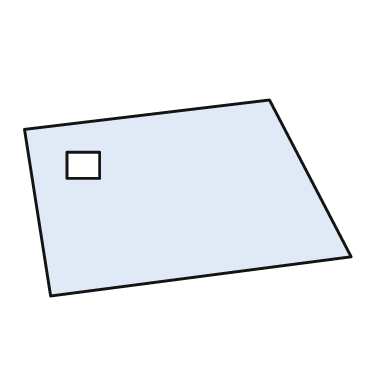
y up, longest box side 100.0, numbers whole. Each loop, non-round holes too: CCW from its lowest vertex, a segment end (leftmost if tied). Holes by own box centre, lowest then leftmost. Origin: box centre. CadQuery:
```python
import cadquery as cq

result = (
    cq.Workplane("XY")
    .moveTo(-42.0, -30.0)
    .lineTo(50.0, -18.0)
    .lineTo(25.0, 30.0)
    .lineTo(-50.0, 21.0)
    .close()
    .moveTo(-37.0, 6.0)
    .lineTo(-27.0, 6.0)
    .lineTo(-27.0, 14.0)
    .lineTo(-37.0, 14.0)
    .close()
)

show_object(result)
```